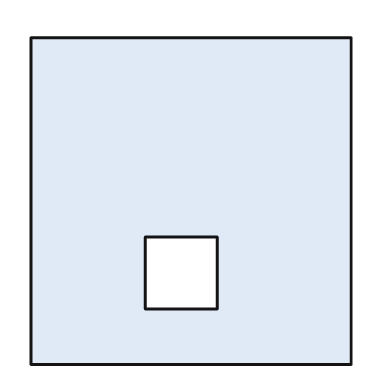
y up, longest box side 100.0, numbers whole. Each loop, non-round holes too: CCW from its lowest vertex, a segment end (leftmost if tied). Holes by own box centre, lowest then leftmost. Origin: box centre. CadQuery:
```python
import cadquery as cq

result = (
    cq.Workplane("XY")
    .moveTo(-49.0, -50.0)
    .lineTo(49.0, -50.0)
    .lineTo(49.0, 50.0)
    .lineTo(-49.0, 50.0)
    .close()
    .moveTo(-14.0, -33.0)
    .lineTo(8.0, -33.0)
    .lineTo(8.0, -11.0)
    .lineTo(-14.0, -11.0)
    .close()
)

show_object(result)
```